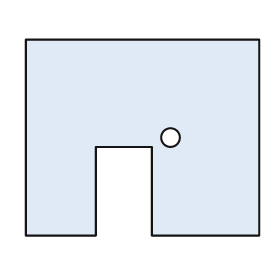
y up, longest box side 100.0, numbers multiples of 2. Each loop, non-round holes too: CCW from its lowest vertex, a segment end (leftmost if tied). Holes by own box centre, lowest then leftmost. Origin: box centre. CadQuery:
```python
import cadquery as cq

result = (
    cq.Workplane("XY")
    .moveTo(-50.0, -42.0)
    .lineTo(-20.0, -42.0)
    .lineTo(-20.0, -4.0)
    .lineTo(4.0, -4.0)
    .lineTo(4.0, -42.0)
    .lineTo(50.0, -42.0)
    .lineTo(50.0, 42.0)
    .lineTo(-50.0, 42.0)
    .close()
    .moveTo(12.0, 0.0)
    .circle(4.0)
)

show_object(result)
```